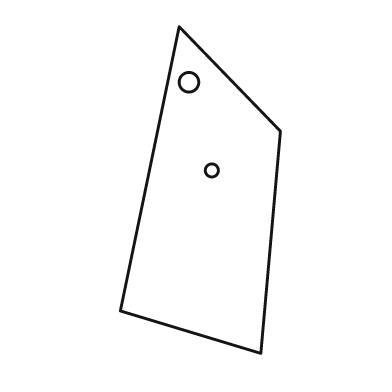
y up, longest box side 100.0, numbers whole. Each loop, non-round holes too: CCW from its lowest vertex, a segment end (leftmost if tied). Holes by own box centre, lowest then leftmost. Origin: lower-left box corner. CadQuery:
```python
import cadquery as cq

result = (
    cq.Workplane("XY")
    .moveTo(43.0, 0.0)
    .lineTo(49.0, 68.0)
    .lineTo(18.0, 100.0)
    .lineTo(0.0, 13.0)
    .close()
    .moveTo(28.0, 56.0)
    .circle(2.0)
    .moveTo(21.0, 83.0)
    .circle(3.0)
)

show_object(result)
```